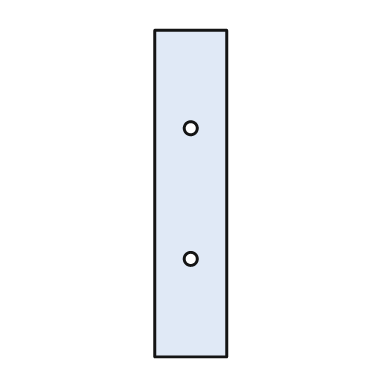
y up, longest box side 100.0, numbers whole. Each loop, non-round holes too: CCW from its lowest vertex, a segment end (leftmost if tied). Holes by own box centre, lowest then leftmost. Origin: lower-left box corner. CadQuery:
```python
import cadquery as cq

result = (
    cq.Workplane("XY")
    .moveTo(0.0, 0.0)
    .lineTo(22.0, 0.0)
    .lineTo(22.0, 100.0)
    .lineTo(0.0, 100.0)
    .close()
    .moveTo(11.0, 30.0)
    .circle(2.0)
    .moveTo(11.0, 70.0)
    .circle(2.0)
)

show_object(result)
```